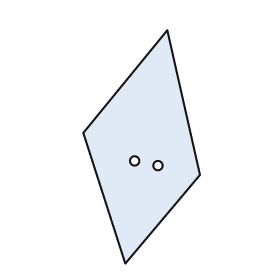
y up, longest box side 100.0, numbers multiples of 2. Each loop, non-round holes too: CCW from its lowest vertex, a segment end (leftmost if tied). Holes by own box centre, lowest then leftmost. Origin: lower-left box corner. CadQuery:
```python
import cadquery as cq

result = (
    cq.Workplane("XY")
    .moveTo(18.0, 0.0)
    .lineTo(50.0, 38.0)
    .lineTo(36.0, 100.0)
    .lineTo(0.0, 56.0)
    .close()
    .moveTo(32.0, 42.0)
    .circle(2.0)
    .moveTo(22.0, 44.0)
    .circle(2.0)
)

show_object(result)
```